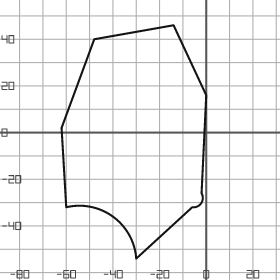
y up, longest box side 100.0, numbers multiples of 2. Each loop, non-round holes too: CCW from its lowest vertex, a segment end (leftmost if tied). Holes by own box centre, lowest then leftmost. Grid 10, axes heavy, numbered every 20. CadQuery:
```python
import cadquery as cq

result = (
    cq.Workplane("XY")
    .moveTo(-30.0, -54.0)
    .lineTo(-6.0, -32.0)
    .threePointArc((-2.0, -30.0), (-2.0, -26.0))
    .lineTo(0.0, 16.0)
    .lineTo(-14.0, 46.0)
    .lineTo(-48.0, 40.0)
    .lineTo(-62.0, 2.0)
    .lineTo(-60.0, -32.0)
    .threePointArc((-40.0, -36.0), (-30.0, -54.0))
    .close()
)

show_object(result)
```